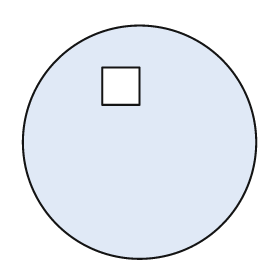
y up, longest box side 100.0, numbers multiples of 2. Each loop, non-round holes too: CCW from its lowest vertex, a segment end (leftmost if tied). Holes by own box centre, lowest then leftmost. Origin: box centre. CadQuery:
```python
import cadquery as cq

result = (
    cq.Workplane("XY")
    .moveTo(0.0, 0.0)
    .circle(50.0)
    .moveTo(-16.0, 16.0)
    .lineTo(0.0, 16.0)
    .lineTo(0.0, 32.0)
    .lineTo(-16.0, 32.0)
    .close()
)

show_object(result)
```